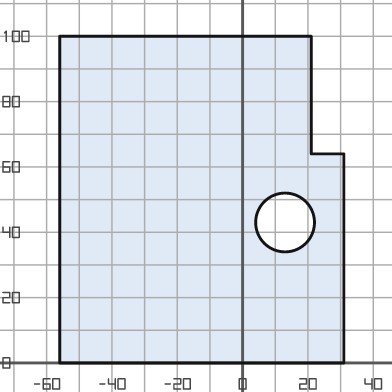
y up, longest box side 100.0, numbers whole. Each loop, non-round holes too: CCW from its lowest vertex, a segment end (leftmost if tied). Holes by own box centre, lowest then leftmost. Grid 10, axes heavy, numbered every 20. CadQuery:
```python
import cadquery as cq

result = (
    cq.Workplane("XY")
    .moveTo(-56.0, 0.0)
    .lineTo(31.0, 0.0)
    .lineTo(31.0, 64.0)
    .lineTo(21.0, 64.0)
    .lineTo(21.0, 100.0)
    .lineTo(-56.0, 100.0)
    .close()
    .moveTo(13.0, 43.0)
    .circle(9.0)
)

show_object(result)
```